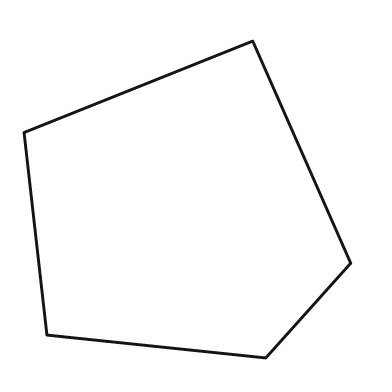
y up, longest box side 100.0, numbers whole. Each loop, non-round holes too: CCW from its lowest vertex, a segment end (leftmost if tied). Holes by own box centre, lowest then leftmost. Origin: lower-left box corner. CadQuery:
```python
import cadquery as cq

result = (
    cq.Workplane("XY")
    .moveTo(74.0, 0.0)
    .lineTo(100.0, 29.0)
    .lineTo(70.0, 97.0)
    .lineTo(0.0, 69.0)
    .lineTo(7.0, 7.0)
    .close()
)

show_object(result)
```